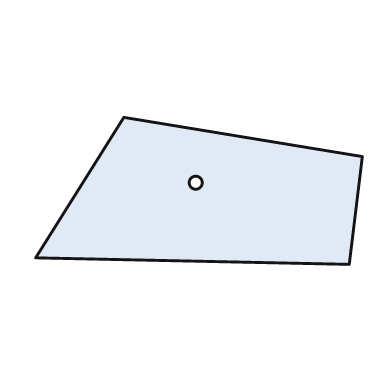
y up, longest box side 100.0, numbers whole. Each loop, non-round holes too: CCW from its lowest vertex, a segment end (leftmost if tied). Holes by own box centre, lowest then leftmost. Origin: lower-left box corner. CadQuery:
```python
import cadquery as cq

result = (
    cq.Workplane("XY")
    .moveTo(96.0, 0.0)
    .lineTo(100.0, 33.0)
    .lineTo(27.0, 45.0)
    .lineTo(0.0, 2.0)
    .close()
    .moveTo(49.0, 25.0)
    .circle(2.0)
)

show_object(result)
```